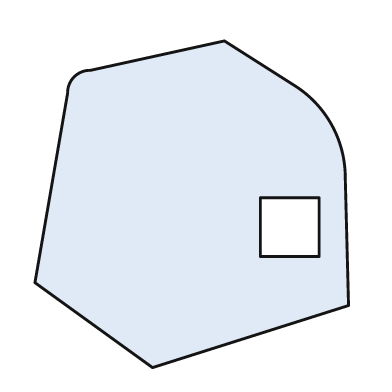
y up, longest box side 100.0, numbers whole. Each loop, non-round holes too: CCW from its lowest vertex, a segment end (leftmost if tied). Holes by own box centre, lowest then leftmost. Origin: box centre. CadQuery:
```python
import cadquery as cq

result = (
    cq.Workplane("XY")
    .moveTo(-12.0, -50.0)
    .lineTo(48.0, -31.0)
    .lineTo(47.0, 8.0)
    .threePointArc((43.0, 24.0), (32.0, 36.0))
    .lineTo(10.0, 50.0)
    .lineTo(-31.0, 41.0)
    .threePointArc((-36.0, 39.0), (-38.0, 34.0))
    .lineTo(-48.0, -24.0)
    .close()
    .moveTo(21.0, -16.0)
    .lineTo(39.0, -16.0)
    .lineTo(39.0, 2.0)
    .lineTo(21.0, 2.0)
    .close()
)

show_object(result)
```